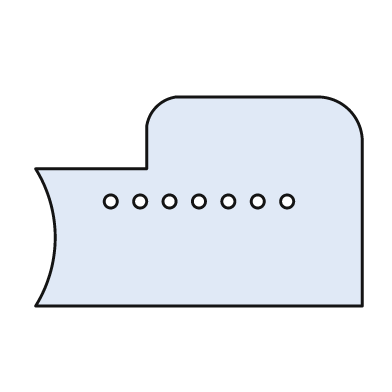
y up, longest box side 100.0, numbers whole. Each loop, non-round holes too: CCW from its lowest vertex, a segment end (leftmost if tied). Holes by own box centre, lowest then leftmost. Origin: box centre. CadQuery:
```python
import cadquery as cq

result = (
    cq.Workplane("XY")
    .moveTo(-50.0, -32.0)
    .lineTo(50.0, -32.0)
    .lineTo(50.0, 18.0)
    .threePointArc((46.0, 28.0), (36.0, 32.0))
    .lineTo(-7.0, 32.0)
    .threePointArc((-13.0, 29.0), (-16.0, 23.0))
    .lineTo(-16.0, 10.0)
    .lineTo(-50.0, 10.0)
    .threePointArc((-44.0, -11.0), (-50.0, -32.0))
    .close()
    .moveTo(-27.0, 0.0)
    .circle(2.0)
    .moveTo(-18.0, 0.0)
    .circle(2.0)
    .moveTo(-9.0, 0.0)
    .circle(2.0)
    .moveTo(0.0, 0.0)
    .circle(2.0)
    .moveTo(9.0, 0.0)
    .circle(2.0)
    .moveTo(18.0, 0.0)
    .circle(2.0)
    .moveTo(27.0, 0.0)
    .circle(2.0)
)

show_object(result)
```